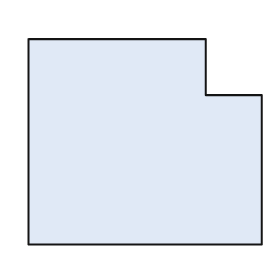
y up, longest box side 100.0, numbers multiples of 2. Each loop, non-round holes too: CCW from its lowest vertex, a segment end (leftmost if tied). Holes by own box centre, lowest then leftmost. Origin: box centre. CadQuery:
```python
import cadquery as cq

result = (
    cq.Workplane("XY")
    .moveTo(-50.0, -44.0)
    .lineTo(50.0, -44.0)
    .lineTo(50.0, 20.0)
    .lineTo(26.0, 20.0)
    .lineTo(26.0, 44.0)
    .lineTo(-50.0, 44.0)
    .close()
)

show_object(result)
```